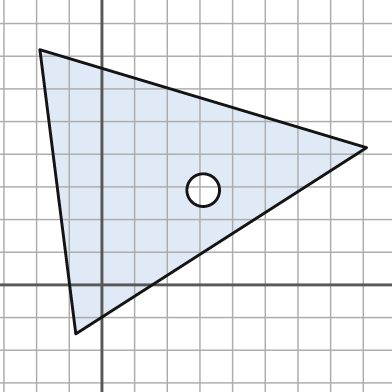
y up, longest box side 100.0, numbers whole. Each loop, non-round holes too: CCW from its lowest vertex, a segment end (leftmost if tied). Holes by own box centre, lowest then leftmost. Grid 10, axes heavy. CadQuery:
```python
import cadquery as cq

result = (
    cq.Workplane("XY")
    .moveTo(-8.0, -15.0)
    .lineTo(81.0, 42.0)
    .lineTo(-19.0, 72.0)
    .close()
    .moveTo(31.0, 29.0)
    .circle(5.0)
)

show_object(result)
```